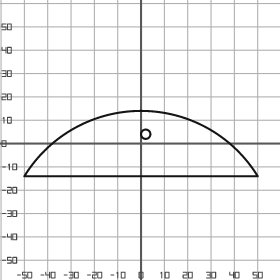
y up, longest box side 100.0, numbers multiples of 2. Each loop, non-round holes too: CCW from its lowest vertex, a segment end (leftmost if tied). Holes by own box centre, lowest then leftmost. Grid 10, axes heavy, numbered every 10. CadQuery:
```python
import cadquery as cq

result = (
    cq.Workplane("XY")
    .moveTo(-50.0, -14.0)
    .lineTo(50.0, -14.0)
    .threePointArc((0.0, 14.0), (-50.0, -14.0))
    .close()
    .moveTo(2.0, 4.0)
    .circle(2.0)
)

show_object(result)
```